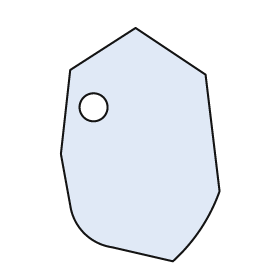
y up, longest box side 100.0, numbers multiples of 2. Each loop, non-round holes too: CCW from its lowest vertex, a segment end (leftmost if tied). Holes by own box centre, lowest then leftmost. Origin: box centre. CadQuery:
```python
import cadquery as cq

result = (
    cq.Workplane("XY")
    .moveTo(14.0, -50.0)
    .threePointArc((26.0, -36.0), (34.0, -20.0))
    .lineTo(28.0, 30.0)
    .lineTo(-2.0, 50.0)
    .lineTo(-30.0, 32.0)
    .lineTo(-34.0, -4.0)
    .lineTo(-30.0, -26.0)
    .threePointArc((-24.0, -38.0), (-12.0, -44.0))
    .close()
    .moveTo(-20.0, 16.0)
    .circle(6.0)
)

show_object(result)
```